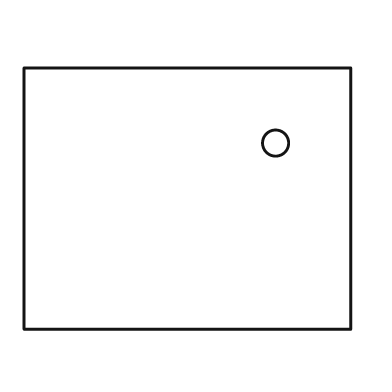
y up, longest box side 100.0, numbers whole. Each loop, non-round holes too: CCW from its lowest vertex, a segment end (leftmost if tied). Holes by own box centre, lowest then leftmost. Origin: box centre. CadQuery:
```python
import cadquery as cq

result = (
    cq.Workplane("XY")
    .moveTo(-50.0, -40.0)
    .lineTo(50.0, -40.0)
    .lineTo(50.0, 40.0)
    .lineTo(-50.0, 40.0)
    .close()
    .moveTo(27.0, 17.0)
    .circle(4.0)
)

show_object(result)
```